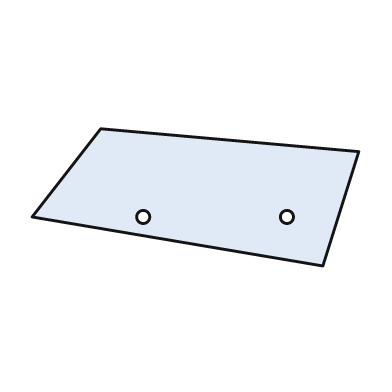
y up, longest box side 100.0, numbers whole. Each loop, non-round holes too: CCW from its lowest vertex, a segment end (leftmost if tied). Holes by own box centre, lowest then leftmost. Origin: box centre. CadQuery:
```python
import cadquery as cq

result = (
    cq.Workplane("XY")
    .moveTo(39.0, -21.0)
    .lineTo(50.0, 14.0)
    .lineTo(-29.0, 21.0)
    .lineTo(-50.0, -6.0)
    .close()
    .moveTo(-16.0, -6.0)
    .circle(2.0)
    .moveTo(28.0, -6.0)
    .circle(2.0)
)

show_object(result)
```